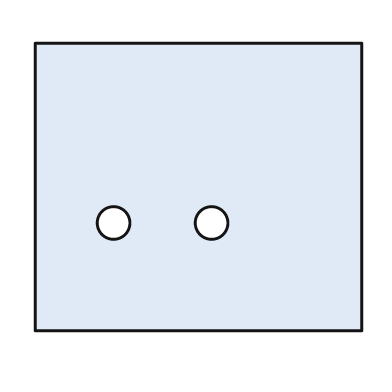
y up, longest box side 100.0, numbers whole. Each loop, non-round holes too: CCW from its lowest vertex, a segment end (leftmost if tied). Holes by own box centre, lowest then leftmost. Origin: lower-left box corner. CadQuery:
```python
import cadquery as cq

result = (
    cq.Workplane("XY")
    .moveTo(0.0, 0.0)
    .lineTo(100.0, 0.0)
    .lineTo(100.0, 88.0)
    .lineTo(0.0, 88.0)
    .close()
    .moveTo(24.0, 33.0)
    .circle(5.0)
    .moveTo(54.0, 33.0)
    .circle(5.0)
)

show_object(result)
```